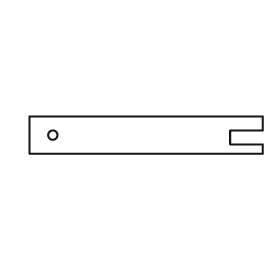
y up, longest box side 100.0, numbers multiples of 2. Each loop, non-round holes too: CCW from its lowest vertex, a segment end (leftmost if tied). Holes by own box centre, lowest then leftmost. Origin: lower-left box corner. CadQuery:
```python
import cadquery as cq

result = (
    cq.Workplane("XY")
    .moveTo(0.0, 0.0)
    .lineTo(100.0, 0.0)
    .lineTo(100.0, 4.0)
    .lineTo(86.0, 4.0)
    .lineTo(86.0, 10.0)
    .lineTo(100.0, 10.0)
    .lineTo(100.0, 16.0)
    .lineTo(0.0, 16.0)
    .close()
    .moveTo(10.0, 8.0)
    .circle(2.0)
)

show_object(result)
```